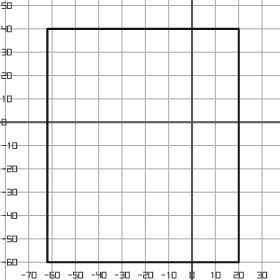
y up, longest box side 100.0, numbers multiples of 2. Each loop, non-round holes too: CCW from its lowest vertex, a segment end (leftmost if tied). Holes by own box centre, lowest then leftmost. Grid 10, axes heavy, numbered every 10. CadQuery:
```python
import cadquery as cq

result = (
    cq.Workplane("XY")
    .moveTo(-62.0, -60.0)
    .lineTo(20.0, -60.0)
    .lineTo(20.0, 40.0)
    .lineTo(-62.0, 40.0)
    .close()
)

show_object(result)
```